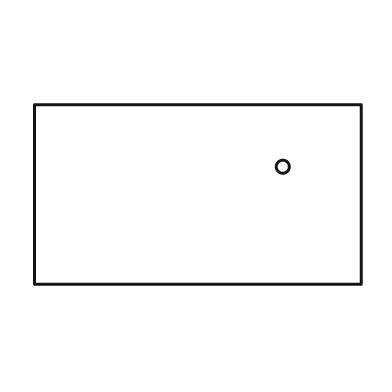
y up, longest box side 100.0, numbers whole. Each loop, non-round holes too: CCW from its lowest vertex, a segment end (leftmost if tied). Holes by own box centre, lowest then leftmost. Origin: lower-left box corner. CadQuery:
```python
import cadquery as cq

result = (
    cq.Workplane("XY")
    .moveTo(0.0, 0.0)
    .lineTo(100.0, 0.0)
    .lineTo(100.0, 55.0)
    .lineTo(0.0, 55.0)
    .close()
    .moveTo(76.0, 36.0)
    .circle(2.0)
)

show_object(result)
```